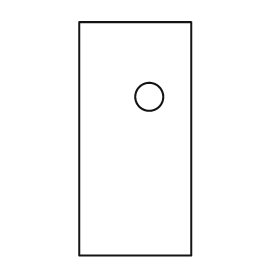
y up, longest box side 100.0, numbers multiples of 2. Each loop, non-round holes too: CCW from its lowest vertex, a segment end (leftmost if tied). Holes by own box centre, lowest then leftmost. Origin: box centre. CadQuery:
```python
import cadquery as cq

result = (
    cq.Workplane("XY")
    .moveTo(-24.0, -50.0)
    .lineTo(24.0, -50.0)
    .lineTo(24.0, 50.0)
    .lineTo(-24.0, 50.0)
    .close()
    .moveTo(6.0, 18.0)
    .circle(6.0)
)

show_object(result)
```